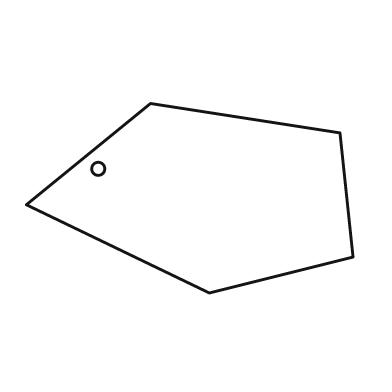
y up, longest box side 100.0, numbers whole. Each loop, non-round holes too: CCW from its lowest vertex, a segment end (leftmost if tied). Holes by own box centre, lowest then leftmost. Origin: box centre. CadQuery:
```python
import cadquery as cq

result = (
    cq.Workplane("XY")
    .moveTo(6.0, -29.0)
    .lineTo(50.0, -18.0)
    .lineTo(46.0, 20.0)
    .lineTo(-12.0, 29.0)
    .lineTo(-50.0, -2.0)
    .close()
    .moveTo(-28.0, 9.0)
    .circle(2.0)
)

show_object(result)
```